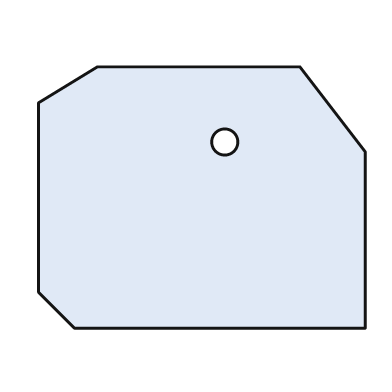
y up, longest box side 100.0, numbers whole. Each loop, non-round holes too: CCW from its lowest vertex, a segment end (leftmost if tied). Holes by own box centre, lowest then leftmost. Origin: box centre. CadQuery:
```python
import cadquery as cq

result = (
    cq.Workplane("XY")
    .moveTo(-39.0, -40.0)
    .lineTo(50.0, -40.0)
    .lineTo(50.0, 14.0)
    .lineTo(30.0, 40.0)
    .lineTo(-32.0, 40.0)
    .lineTo(-50.0, 29.0)
    .lineTo(-50.0, -29.0)
    .close()
    .moveTo(7.0, 17.0)
    .circle(4.0)
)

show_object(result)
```